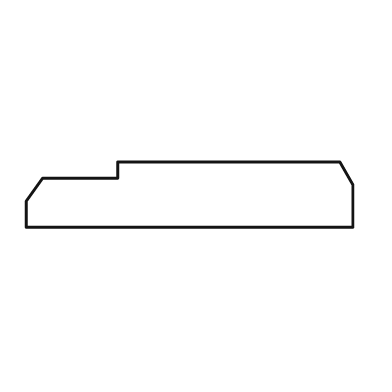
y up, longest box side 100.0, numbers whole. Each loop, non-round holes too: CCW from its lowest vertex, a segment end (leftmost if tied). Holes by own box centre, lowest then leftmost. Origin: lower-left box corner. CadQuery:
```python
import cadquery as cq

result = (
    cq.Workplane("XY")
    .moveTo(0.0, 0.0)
    .lineTo(100.0, 0.0)
    .lineTo(100.0, 13.0)
    .lineTo(96.0, 20.0)
    .lineTo(28.0, 20.0)
    .lineTo(28.0, 15.0)
    .lineTo(5.0, 15.0)
    .lineTo(0.0, 8.0)
    .close()
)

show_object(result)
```